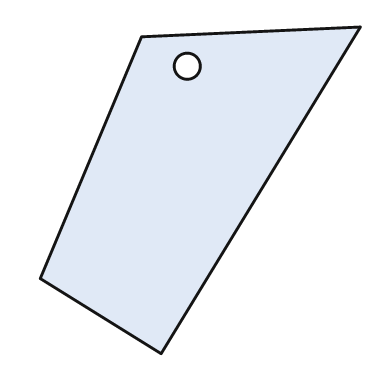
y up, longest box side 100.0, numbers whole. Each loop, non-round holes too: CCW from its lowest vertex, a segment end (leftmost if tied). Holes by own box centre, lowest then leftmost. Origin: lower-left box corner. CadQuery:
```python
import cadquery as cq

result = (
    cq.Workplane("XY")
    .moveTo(37.0, 0.0)
    .lineTo(98.0, 100.0)
    .lineTo(31.0, 97.0)
    .lineTo(0.0, 23.0)
    .close()
    .moveTo(45.0, 88.0)
    .circle(4.0)
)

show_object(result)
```